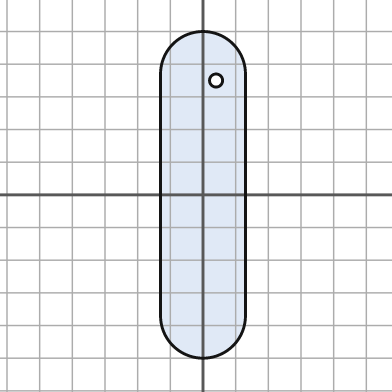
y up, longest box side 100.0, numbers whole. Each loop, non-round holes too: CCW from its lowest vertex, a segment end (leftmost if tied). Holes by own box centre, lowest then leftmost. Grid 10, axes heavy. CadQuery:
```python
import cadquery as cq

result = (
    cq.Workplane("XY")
    .moveTo(-13.0, -37.0)
    .threePointArc((0.0, -50.0), (13.0, -37.0))
    .lineTo(13.0, 37.0)
    .threePointArc((0.0, 50.0), (-13.0, 37.0))
    .close()
    .moveTo(4.0, 35.0)
    .circle(2.0)
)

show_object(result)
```